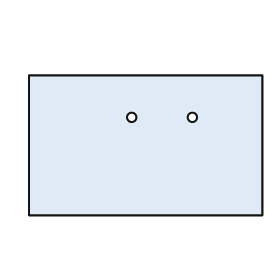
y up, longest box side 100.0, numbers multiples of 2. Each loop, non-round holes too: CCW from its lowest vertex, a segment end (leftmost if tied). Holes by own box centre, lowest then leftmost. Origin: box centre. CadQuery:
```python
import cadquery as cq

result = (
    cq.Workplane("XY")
    .moveTo(-50.0, -30.0)
    .lineTo(50.0, -30.0)
    .lineTo(50.0, 30.0)
    .lineTo(-50.0, 30.0)
    .close()
    .moveTo(-6.0, 12.0)
    .circle(2.0)
    .moveTo(20.0, 12.0)
    .circle(2.0)
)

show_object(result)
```